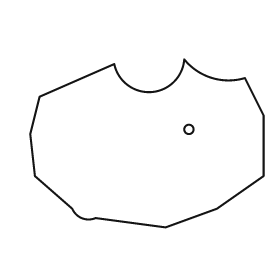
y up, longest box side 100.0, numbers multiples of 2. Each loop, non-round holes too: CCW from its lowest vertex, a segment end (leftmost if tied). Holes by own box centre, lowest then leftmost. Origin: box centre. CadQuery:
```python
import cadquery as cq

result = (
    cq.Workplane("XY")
    .moveTo(8.0, -36.0)
    .lineTo(30.0, -28.0)
    .lineTo(50.0, -14.0)
    .lineTo(50.0, 12.0)
    .lineTo(42.0, 28.0)
    .threePointArc((28.0, 28.0), (16.0, 36.0))
    .threePointArc((2.0, 22.0), (-14.0, 34.0))
    .lineTo(-46.0, 20.0)
    .lineTo(-50.0, 4.0)
    .lineTo(-48.0, -14.0)
    .lineTo(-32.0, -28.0)
    .threePointArc((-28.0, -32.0), (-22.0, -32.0))
    .close()
    .moveTo(18.0, 6.0)
    .circle(2.0)
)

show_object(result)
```